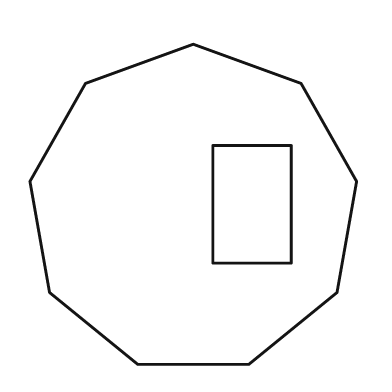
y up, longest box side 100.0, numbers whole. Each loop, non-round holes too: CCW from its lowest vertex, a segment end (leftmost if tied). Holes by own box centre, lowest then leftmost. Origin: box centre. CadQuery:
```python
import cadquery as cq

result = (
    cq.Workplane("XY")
    .moveTo(-17.0, -49.0)
    .lineTo(17.0, -49.0)
    .lineTo(44.0, -27.0)
    .lineTo(50.0, 7.0)
    .lineTo(33.0, 37.0)
    .lineTo(0.0, 49.0)
    .lineTo(-33.0, 37.0)
    .lineTo(-50.0, 7.0)
    .lineTo(-44.0, -27.0)
    .close()
    .moveTo(6.0, -18.0)
    .lineTo(30.0, -18.0)
    .lineTo(30.0, 18.0)
    .lineTo(6.0, 18.0)
    .close()
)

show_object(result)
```